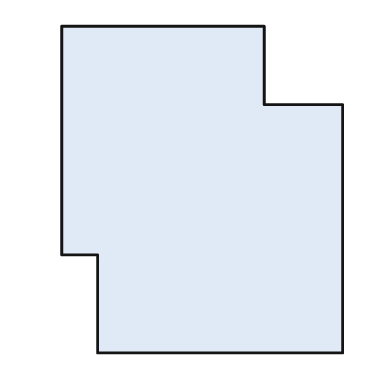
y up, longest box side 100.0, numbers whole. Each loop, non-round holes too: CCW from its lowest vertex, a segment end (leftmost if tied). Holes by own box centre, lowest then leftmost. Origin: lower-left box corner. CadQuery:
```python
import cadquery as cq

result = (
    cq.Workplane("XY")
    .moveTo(11.0, 0.0)
    .lineTo(86.0, 0.0)
    .lineTo(86.0, 76.0)
    .lineTo(62.0, 76.0)
    .lineTo(62.0, 100.0)
    .lineTo(0.0, 100.0)
    .lineTo(0.0, 30.0)
    .lineTo(11.0, 30.0)
    .close()
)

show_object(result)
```